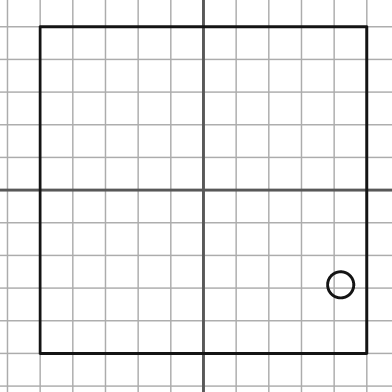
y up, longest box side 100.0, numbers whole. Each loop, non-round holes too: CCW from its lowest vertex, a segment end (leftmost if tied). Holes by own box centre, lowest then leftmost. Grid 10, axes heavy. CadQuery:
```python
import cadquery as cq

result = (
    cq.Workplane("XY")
    .moveTo(-50.0, -50.0)
    .lineTo(50.0, -50.0)
    .lineTo(50.0, 50.0)
    .lineTo(-50.0, 50.0)
    .close()
    .moveTo(42.0, -29.0)
    .circle(4.0)
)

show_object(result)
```